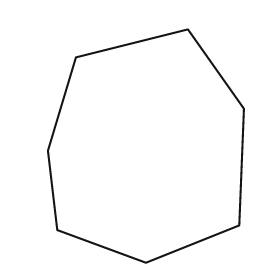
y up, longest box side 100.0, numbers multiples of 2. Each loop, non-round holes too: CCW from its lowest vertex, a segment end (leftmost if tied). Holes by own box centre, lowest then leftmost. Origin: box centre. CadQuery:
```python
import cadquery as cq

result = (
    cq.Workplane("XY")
    .moveTo(0.0, -50.0)
    .lineTo(40.0, -34.0)
    .lineTo(42.0, 16.0)
    .lineTo(18.0, 50.0)
    .lineTo(-30.0, 38.0)
    .lineTo(-42.0, -2.0)
    .lineTo(-38.0, -36.0)
    .close()
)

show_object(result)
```